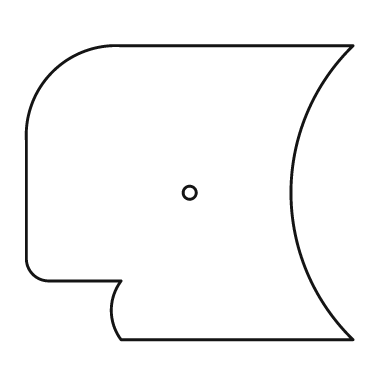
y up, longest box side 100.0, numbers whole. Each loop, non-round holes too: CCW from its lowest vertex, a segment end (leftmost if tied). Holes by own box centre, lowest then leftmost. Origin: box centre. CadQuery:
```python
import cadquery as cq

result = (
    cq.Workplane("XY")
    .moveTo(-21.0, -45.0)
    .lineTo(50.0, -45.0)
    .threePointArc((31.0, 0.0), (50.0, 45.0))
    .lineTo(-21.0, 45.0)
    .threePointArc((-42.0, 37.0), (-50.0, 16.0))
    .lineTo(-50.0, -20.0)
    .threePointArc((-48.0, -25.0), (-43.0, -27.0))
    .lineTo(-21.0, -27.0)
    .threePointArc((-24.0, -36.0), (-21.0, -45.0))
    .close()
    .moveTo(0.0, 0.0)
    .circle(2.0)
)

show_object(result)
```